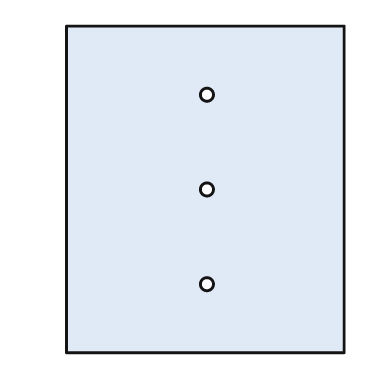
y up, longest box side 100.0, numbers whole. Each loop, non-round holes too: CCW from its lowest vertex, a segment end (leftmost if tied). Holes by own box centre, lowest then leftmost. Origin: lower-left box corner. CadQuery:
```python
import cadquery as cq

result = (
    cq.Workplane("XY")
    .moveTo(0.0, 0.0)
    .lineTo(85.0, 0.0)
    .lineTo(85.0, 100.0)
    .lineTo(0.0, 100.0)
    .close()
    .moveTo(43.0, 21.0)
    .circle(2.0)
    .moveTo(43.0, 50.0)
    .circle(2.0)
    .moveTo(43.0, 79.0)
    .circle(2.0)
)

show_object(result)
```